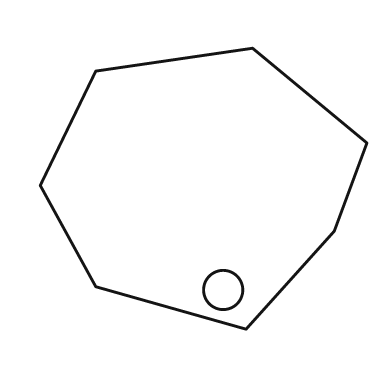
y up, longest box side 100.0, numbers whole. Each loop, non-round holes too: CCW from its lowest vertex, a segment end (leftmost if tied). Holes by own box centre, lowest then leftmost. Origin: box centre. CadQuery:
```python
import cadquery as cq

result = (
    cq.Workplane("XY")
    .moveTo(13.0, -43.0)
    .lineTo(40.0, -13.0)
    .lineTo(50.0, 14.0)
    .lineTo(15.0, 43.0)
    .lineTo(-33.0, 36.0)
    .lineTo(-50.0, 1.0)
    .lineTo(-33.0, -30.0)
    .close()
    .moveTo(6.0, -31.0)
    .circle(6.0)
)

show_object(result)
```